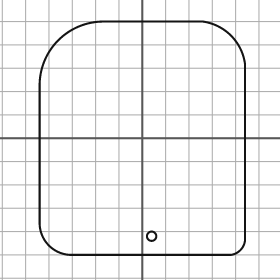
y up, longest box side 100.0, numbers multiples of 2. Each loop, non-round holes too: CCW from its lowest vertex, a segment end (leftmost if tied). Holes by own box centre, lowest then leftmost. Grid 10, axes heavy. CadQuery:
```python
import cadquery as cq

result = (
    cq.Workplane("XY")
    .moveTo(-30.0, -50.0)
    .lineTo(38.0, -50.0)
    .threePointArc((42.0, -48.0), (44.0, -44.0))
    .lineTo(44.0, 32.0)
    .threePointArc((38.0, 44.0), (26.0, 50.0))
    .lineTo(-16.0, 50.0)
    .threePointArc((-36.0, 42.0), (-44.0, 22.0))
    .lineTo(-44.0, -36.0)
    .threePointArc((-40.0, -46.0), (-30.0, -50.0))
    .close()
    .moveTo(4.0, -42.0)
    .circle(2.0)
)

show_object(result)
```